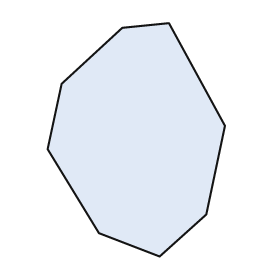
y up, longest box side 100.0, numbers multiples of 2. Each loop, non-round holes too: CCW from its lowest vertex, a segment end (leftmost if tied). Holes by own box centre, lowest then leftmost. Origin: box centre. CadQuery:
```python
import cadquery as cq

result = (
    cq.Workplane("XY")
    .moveTo(10.0, -50.0)
    .lineTo(30.0, -32.0)
    .lineTo(38.0, 6.0)
    .lineTo(14.0, 50.0)
    .lineTo(-6.0, 48.0)
    .lineTo(-32.0, 24.0)
    .lineTo(-38.0, -4.0)
    .lineTo(-16.0, -40.0)
    .close()
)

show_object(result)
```